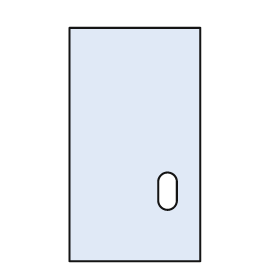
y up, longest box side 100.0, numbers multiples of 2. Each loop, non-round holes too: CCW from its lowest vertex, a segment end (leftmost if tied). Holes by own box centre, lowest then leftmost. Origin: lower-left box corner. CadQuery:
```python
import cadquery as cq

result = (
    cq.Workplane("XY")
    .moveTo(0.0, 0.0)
    .lineTo(56.0, 0.0)
    .lineTo(56.0, 100.0)
    .lineTo(0.0, 100.0)
    .close()
    .moveTo(38.0, 26.0)
    .threePointArc((42.0, 22.0), (46.0, 26.0))
    .lineTo(46.0, 34.0)
    .threePointArc((42.0, 38.0), (38.0, 34.0))
    .close()
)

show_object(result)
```